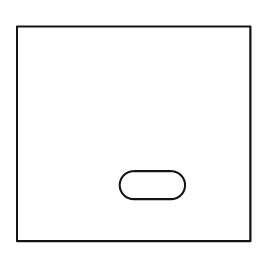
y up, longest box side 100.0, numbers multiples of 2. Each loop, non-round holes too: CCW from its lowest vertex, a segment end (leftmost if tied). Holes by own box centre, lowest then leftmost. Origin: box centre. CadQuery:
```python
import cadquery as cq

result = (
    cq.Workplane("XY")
    .moveTo(-50.0, -46.0)
    .lineTo(50.0, -46.0)
    .lineTo(50.0, 46.0)
    .lineTo(-50.0, 46.0)
    .close()
    .moveTo(0.0, -28.0)
    .lineTo(16.0, -28.0)
    .threePointArc((22.0, -22.0), (16.0, -16.0))
    .lineTo(0.0, -16.0)
    .threePointArc((-6.0, -22.0), (0.0, -28.0))
    .close()
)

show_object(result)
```